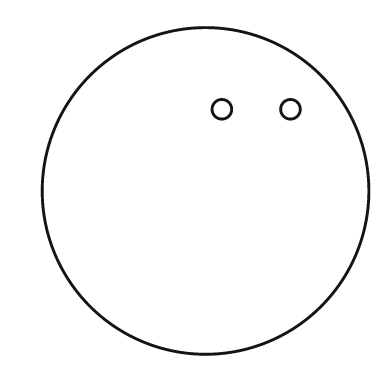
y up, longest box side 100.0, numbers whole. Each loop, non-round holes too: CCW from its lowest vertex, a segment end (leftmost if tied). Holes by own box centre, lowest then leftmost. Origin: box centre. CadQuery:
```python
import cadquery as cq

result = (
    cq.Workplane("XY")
    .moveTo(0.0, 0.0)
    .circle(50.0)
    .moveTo(5.0, 25.0)
    .circle(3.0)
    .moveTo(26.0, 25.0)
    .circle(3.0)
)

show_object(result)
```